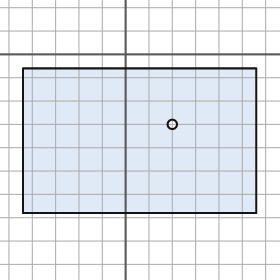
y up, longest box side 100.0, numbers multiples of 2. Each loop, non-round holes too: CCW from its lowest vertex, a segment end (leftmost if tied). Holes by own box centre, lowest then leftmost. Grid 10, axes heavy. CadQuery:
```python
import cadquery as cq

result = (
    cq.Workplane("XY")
    .moveTo(-44.0, -68.0)
    .lineTo(56.0, -68.0)
    .lineTo(56.0, -6.0)
    .lineTo(-44.0, -6.0)
    .close()
    .moveTo(20.0, -30.0)
    .circle(2.0)
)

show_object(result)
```